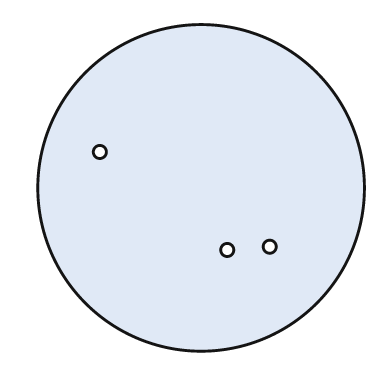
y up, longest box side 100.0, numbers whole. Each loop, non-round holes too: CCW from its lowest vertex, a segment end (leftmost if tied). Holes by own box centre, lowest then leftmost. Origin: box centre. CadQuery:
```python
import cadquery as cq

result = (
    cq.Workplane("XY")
    .moveTo(0.0, 0.0)
    .circle(50.0)
    .moveTo(8.0, -19.0)
    .circle(2.0)
    .moveTo(21.0, -18.0)
    .circle(2.0)
    .moveTo(-31.0, 11.0)
    .circle(2.0)
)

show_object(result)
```